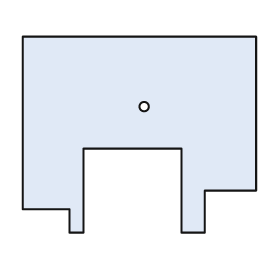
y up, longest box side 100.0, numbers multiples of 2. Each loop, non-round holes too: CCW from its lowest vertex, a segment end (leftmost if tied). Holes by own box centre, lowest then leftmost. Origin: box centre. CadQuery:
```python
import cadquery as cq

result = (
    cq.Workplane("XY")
    .moveTo(-30.0, -42.0)
    .lineTo(-24.0, -42.0)
    .lineTo(-24.0, -6.0)
    .lineTo(18.0, -6.0)
    .lineTo(18.0, -42.0)
    .lineTo(28.0, -42.0)
    .lineTo(28.0, -24.0)
    .lineTo(50.0, -24.0)
    .lineTo(50.0, 42.0)
    .lineTo(-50.0, 42.0)
    .lineTo(-50.0, -32.0)
    .lineTo(-30.0, -32.0)
    .close()
    .moveTo(2.0, 12.0)
    .circle(2.0)
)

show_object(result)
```